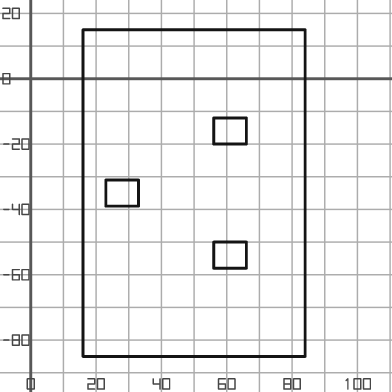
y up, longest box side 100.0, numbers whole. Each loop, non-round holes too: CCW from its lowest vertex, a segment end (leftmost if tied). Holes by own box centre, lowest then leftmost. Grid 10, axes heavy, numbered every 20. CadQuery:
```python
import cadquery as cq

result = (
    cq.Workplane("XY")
    .moveTo(16.0, -85.0)
    .lineTo(84.0, -85.0)
    .lineTo(84.0, 15.0)
    .lineTo(16.0, 15.0)
    .close()
    .moveTo(56.0, -58.0)
    .lineTo(66.0, -58.0)
    .lineTo(66.0, -50.0)
    .lineTo(56.0, -50.0)
    .close()
    .moveTo(23.0, -39.0)
    .lineTo(33.0, -39.0)
    .lineTo(33.0, -31.0)
    .lineTo(23.0, -31.0)
    .close()
    .moveTo(56.0, -20.0)
    .lineTo(66.0, -20.0)
    .lineTo(66.0, -12.0)
    .lineTo(56.0, -12.0)
    .close()
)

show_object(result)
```